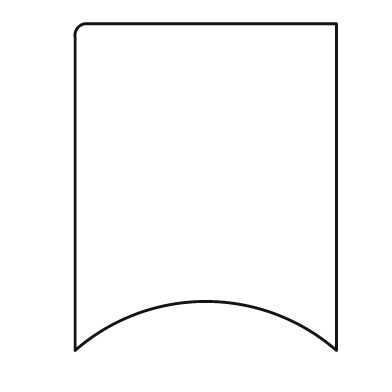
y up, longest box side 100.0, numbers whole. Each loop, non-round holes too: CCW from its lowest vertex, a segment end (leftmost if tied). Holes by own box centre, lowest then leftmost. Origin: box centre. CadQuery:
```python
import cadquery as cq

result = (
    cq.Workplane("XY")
    .moveTo(-40.0, -50.0)
    .threePointArc((0.0, -35.0), (40.0, -50.0))
    .lineTo(40.0, 50.0)
    .lineTo(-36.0, 50.0)
    .threePointArc((-39.0, 49.0), (-40.0, 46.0))
    .close()
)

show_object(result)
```